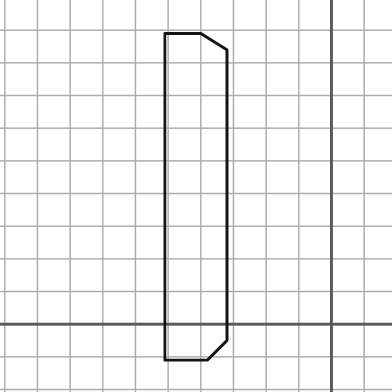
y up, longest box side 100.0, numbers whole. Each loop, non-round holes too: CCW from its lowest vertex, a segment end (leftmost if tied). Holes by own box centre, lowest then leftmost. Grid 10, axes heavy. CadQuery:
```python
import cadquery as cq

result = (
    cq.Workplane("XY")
    .moveTo(-51.0, -11.0)
    .lineTo(-38.0, -11.0)
    .lineTo(-32.0, -5.0)
    .lineTo(-32.0, 84.0)
    .lineTo(-40.0, 89.0)
    .lineTo(-51.0, 89.0)
    .close()
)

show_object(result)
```